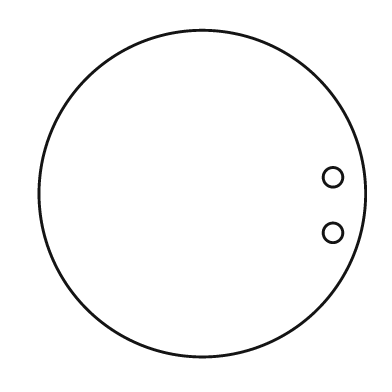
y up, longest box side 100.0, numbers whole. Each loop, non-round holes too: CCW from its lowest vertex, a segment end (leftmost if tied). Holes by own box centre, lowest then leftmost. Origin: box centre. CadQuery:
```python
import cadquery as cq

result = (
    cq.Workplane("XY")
    .moveTo(0.0, 0.0)
    .circle(50.0)
    .moveTo(40.0, -12.0)
    .circle(3.0)
    .moveTo(40.0, 5.0)
    .circle(3.0)
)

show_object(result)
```